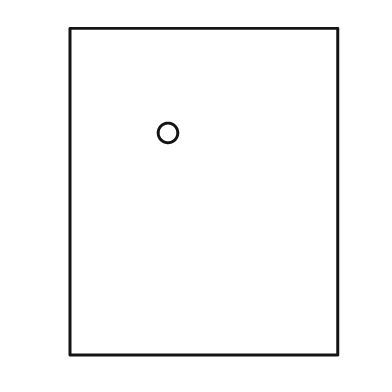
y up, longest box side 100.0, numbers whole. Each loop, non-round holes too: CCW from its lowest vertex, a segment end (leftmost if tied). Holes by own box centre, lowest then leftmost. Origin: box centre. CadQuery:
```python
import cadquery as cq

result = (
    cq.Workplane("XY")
    .moveTo(-41.0, -50.0)
    .lineTo(41.0, -50.0)
    .lineTo(41.0, 50.0)
    .lineTo(-41.0, 50.0)
    .close()
    .moveTo(-11.0, 18.0)
    .circle(3.0)
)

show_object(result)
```